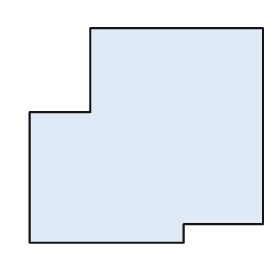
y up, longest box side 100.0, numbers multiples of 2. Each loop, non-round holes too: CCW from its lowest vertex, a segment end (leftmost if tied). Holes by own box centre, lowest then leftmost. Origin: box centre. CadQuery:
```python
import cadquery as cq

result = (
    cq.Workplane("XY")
    .moveTo(-50.0, -46.0)
    .lineTo(16.0, -46.0)
    .lineTo(16.0, -38.0)
    .lineTo(50.0, -38.0)
    .lineTo(50.0, 46.0)
    .lineTo(-24.0, 46.0)
    .lineTo(-24.0, 10.0)
    .lineTo(-50.0, 10.0)
    .close()
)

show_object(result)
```